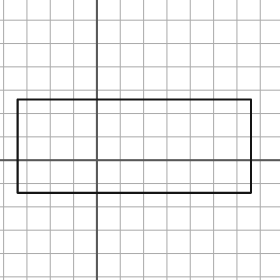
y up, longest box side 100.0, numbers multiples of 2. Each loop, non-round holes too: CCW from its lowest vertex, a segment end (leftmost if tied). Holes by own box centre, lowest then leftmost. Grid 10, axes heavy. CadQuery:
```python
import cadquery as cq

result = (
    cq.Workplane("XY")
    .moveTo(-34.0, -14.0)
    .lineTo(66.0, -14.0)
    .lineTo(66.0, 26.0)
    .lineTo(-34.0, 26.0)
    .close()
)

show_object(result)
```